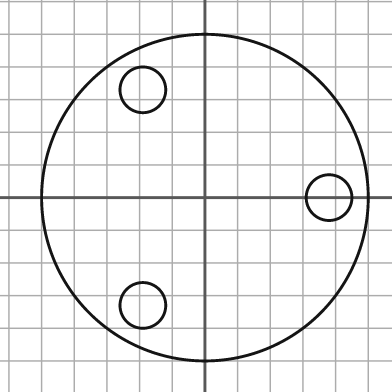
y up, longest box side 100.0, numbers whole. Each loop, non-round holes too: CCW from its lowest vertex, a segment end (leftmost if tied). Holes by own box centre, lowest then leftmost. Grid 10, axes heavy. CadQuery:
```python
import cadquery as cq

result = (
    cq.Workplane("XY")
    .moveTo(0.0, 0.0)
    .circle(50.0)
    .moveTo(-19.0, -33.0)
    .circle(7.0)
    .moveTo(38.0, 0.0)
    .circle(7.0)
    .moveTo(-19.0, 33.0)
    .circle(7.0)
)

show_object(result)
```